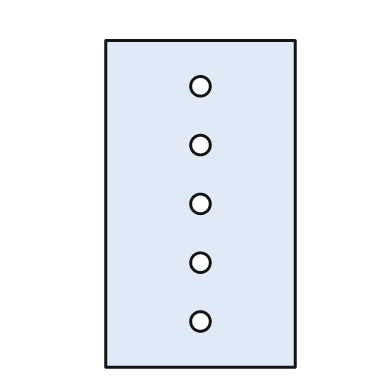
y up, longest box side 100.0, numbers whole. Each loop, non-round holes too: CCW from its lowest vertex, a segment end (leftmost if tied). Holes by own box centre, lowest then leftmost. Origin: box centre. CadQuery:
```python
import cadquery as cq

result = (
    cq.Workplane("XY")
    .moveTo(-29.0, -50.0)
    .lineTo(29.0, -50.0)
    .lineTo(29.0, 50.0)
    .lineTo(-29.0, 50.0)
    .close()
    .moveTo(0.0, -36.0)
    .circle(3.0)
    .moveTo(0.0, -18.0)
    .circle(3.0)
    .moveTo(0.0, 0.0)
    .circle(3.0)
    .moveTo(0.0, 18.0)
    .circle(3.0)
    .moveTo(0.0, 36.0)
    .circle(3.0)
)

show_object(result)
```